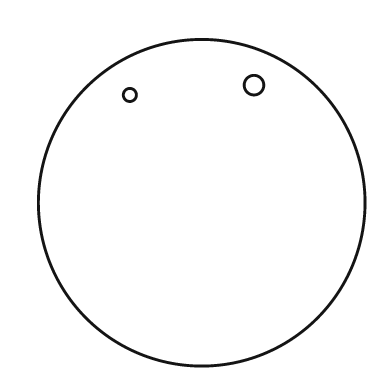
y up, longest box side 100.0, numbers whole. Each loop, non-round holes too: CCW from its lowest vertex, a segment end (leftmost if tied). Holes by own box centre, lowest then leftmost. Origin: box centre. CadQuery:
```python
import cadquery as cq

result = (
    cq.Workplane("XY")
    .moveTo(0.0, 0.0)
    .circle(50.0)
    .moveTo(-22.0, 33.0)
    .circle(2.0)
    .moveTo(16.0, 36.0)
    .circle(3.0)
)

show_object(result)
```